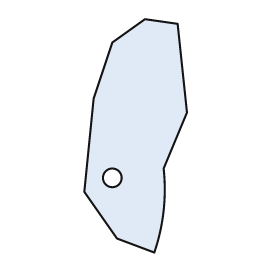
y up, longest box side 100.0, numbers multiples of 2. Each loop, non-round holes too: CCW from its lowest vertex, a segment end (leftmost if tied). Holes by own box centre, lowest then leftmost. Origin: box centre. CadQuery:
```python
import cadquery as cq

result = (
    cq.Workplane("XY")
    .moveTo(8.0, -50.0)
    .threePointArc((12.0, -32.0), (12.0, -14.0))
    .lineTo(22.0, 10.0)
    .lineTo(18.0, 48.0)
    .lineTo(4.0, 50.0)
    .lineTo(-10.0, 40.0)
    .lineTo(-18.0, 16.0)
    .lineTo(-22.0, -24.0)
    .lineTo(-8.0, -44.0)
    .close()
    .moveTo(-10.0, -18.0)
    .circle(4.0)
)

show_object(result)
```